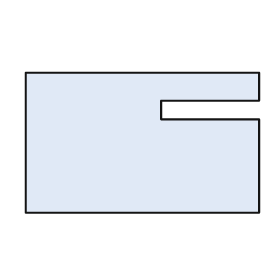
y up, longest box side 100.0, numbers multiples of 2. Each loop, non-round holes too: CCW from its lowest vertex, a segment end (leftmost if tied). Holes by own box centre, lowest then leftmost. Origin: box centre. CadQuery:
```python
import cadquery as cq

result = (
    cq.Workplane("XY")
    .moveTo(-50.0, -30.0)
    .lineTo(50.0, -30.0)
    .lineTo(50.0, 10.0)
    .lineTo(8.0, 10.0)
    .lineTo(8.0, 18.0)
    .lineTo(50.0, 18.0)
    .lineTo(50.0, 30.0)
    .lineTo(-50.0, 30.0)
    .close()
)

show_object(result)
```